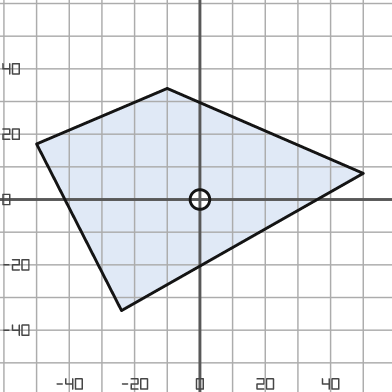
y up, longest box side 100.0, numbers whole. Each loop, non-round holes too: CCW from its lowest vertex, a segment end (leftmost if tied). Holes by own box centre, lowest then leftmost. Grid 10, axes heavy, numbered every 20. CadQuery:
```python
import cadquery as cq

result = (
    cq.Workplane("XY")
    .moveTo(-24.0, -34.0)
    .lineTo(50.0, 8.0)
    .lineTo(-10.0, 34.0)
    .lineTo(-50.0, 17.0)
    .close()
    .moveTo(0.0, 0.0)
    .circle(3.0)
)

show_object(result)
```